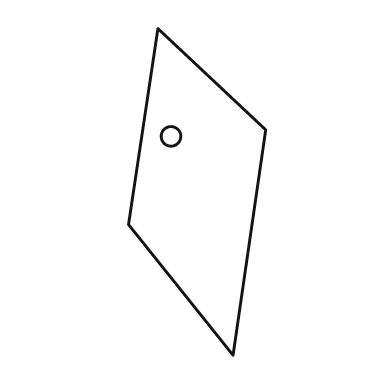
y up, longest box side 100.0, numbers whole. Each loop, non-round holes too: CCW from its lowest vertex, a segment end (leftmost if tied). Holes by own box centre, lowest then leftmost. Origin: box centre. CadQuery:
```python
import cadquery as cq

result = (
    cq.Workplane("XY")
    .moveTo(11.0, -50.0)
    .lineTo(21.0, 19.0)
    .lineTo(-12.0, 50.0)
    .lineTo(-21.0, -10.0)
    .close()
    .moveTo(-8.0, 17.0)
    .circle(3.0)
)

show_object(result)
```